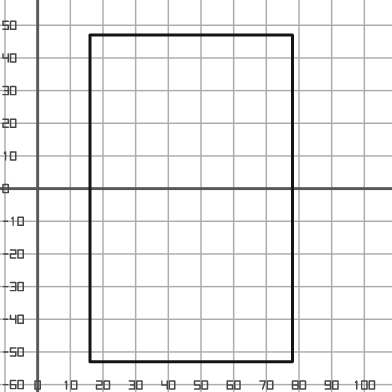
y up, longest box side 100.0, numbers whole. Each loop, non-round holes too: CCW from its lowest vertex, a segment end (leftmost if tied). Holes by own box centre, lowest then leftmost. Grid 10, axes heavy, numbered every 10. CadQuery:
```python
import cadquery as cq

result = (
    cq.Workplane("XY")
    .moveTo(16.0, -53.0)
    .lineTo(78.0, -53.0)
    .lineTo(78.0, 47.0)
    .lineTo(16.0, 47.0)
    .close()
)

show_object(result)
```